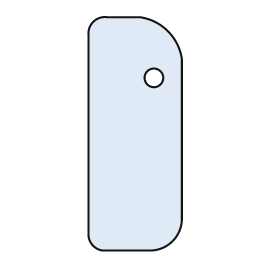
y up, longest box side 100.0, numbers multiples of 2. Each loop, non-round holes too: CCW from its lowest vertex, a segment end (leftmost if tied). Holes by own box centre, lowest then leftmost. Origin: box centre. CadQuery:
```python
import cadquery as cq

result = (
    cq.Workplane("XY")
    .moveTo(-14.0, -50.0)
    .lineTo(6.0, -50.0)
    .threePointArc((16.0, -46.0), (20.0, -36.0))
    .lineTo(20.0, 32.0)
    .threePointArc((14.0, 44.0), (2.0, 50.0))
    .lineTo(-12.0, 50.0)
    .threePointArc((-18.0, 48.0), (-20.0, 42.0))
    .lineTo(-20.0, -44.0)
    .threePointArc((-18.0, -48.0), (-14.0, -50.0))
    .close()
    .moveTo(8.0, 24.0)
    .circle(4.0)
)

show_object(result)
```